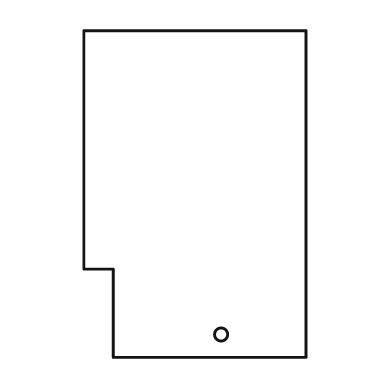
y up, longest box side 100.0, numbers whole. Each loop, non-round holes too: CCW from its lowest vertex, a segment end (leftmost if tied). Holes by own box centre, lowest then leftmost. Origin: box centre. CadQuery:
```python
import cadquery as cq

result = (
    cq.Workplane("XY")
    .moveTo(-25.0, -50.0)
    .lineTo(34.0, -50.0)
    .lineTo(34.0, 50.0)
    .lineTo(-34.0, 50.0)
    .lineTo(-34.0, -23.0)
    .lineTo(-25.0, -23.0)
    .close()
    .moveTo(8.0, -43.0)
    .circle(2.0)
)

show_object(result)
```